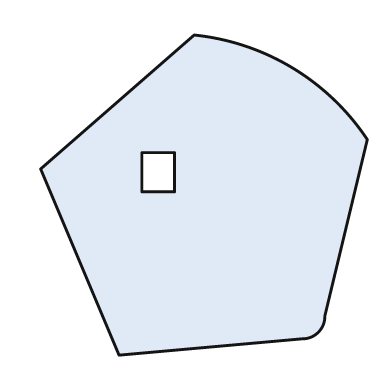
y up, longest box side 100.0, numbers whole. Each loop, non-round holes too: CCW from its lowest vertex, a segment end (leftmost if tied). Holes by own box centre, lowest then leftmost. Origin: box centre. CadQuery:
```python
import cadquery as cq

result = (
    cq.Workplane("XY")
    .moveTo(-26.0, -49.0)
    .lineTo(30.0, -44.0)
    .threePointArc((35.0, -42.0), (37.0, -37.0))
    .lineTo(50.0, 17.0)
    .threePointArc((27.0, 39.0), (-3.0, 49.0))
    .lineTo(-50.0, 8.0)
    .close()
    .moveTo(-19.0, 1.0)
    .lineTo(-9.0, 1.0)
    .lineTo(-9.0, 13.0)
    .lineTo(-19.0, 13.0)
    .close()
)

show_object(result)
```